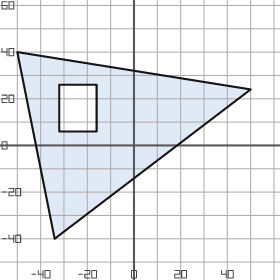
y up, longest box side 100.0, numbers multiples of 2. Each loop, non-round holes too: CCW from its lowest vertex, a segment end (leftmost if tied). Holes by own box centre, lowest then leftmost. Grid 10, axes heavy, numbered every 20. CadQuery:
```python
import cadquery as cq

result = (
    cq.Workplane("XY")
    .moveTo(-34.0, -40.0)
    .lineTo(50.0, 24.0)
    .lineTo(-50.0, 40.0)
    .close()
    .moveTo(-32.0, 6.0)
    .lineTo(-16.0, 6.0)
    .lineTo(-16.0, 26.0)
    .lineTo(-32.0, 26.0)
    .close()
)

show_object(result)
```